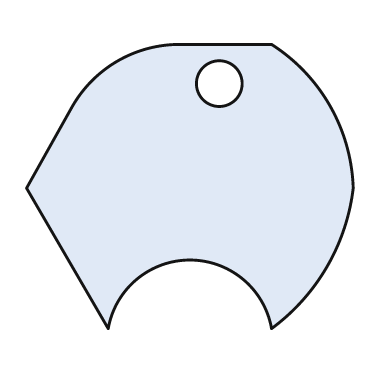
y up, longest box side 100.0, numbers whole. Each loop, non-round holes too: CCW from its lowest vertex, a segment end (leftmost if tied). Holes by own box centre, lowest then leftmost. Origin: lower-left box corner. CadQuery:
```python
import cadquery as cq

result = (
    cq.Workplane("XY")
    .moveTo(25.0, 0.0)
    .threePointArc((50.0, 21.0), (75.0, 0.0))
    .threePointArc((92.0, 19.0), (100.0, 43.0))
    .threePointArc((93.0, 68.0), (75.0, 87.0))
    .lineTo(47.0, 87.0)
    .threePointArc((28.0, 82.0), (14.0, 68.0))
    .lineTo(0.0, 43.0)
    .close()
    .moveTo(59.0, 75.0)
    .circle(7.0)
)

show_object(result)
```